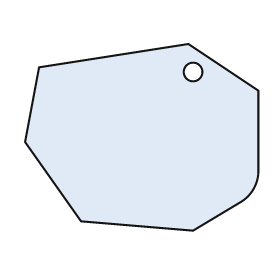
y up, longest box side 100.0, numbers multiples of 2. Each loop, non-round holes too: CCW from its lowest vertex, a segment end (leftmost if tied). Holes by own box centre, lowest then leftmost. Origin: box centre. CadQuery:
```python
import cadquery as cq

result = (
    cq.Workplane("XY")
    .moveTo(22.0, -40.0)
    .lineTo(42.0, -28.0)
    .threePointArc((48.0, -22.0), (50.0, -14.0))
    .lineTo(50.0, 20.0)
    .lineTo(20.0, 40.0)
    .lineTo(-44.0, 30.0)
    .lineTo(-50.0, -2.0)
    .lineTo(-26.0, -36.0)
    .close()
    .moveTo(22.0, 28.0)
    .circle(4.0)
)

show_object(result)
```